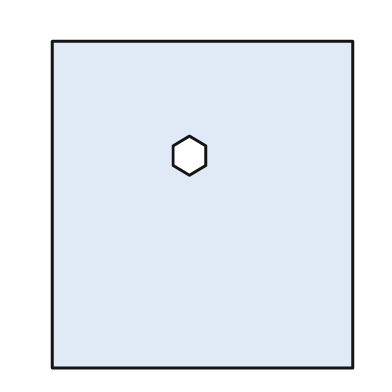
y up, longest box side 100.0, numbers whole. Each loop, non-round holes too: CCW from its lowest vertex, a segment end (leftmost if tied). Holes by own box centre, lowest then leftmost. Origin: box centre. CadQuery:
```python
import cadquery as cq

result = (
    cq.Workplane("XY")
    .moveTo(-46.0, -50.0)
    .lineTo(46.0, -50.0)
    .lineTo(46.0, 50.0)
    .lineTo(-46.0, 50.0)
    .close()
    .moveTo(-4.0, 9.0)
    .lineTo(1.0, 12.0)
    .lineTo(1.0, 18.0)
    .lineTo(-4.0, 21.0)
    .lineTo(-9.0, 18.0)
    .lineTo(-9.0, 12.0)
    .close()
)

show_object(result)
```